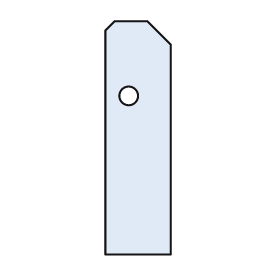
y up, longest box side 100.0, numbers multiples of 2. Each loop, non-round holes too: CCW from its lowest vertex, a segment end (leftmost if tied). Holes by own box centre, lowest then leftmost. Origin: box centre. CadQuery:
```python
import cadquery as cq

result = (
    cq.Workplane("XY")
    .moveTo(-14.0, -50.0)
    .lineTo(14.0, -50.0)
    .lineTo(14.0, 40.0)
    .lineTo(4.0, 50.0)
    .lineTo(-10.0, 50.0)
    .lineTo(-14.0, 46.0)
    .close()
    .moveTo(-4.0, 18.0)
    .circle(4.0)
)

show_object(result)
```